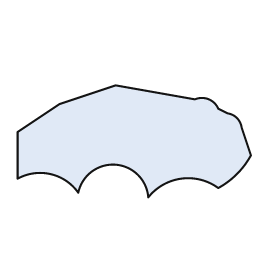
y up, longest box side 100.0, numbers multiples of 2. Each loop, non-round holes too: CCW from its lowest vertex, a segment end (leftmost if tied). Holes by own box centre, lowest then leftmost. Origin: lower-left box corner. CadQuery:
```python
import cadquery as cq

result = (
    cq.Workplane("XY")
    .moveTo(56.0, 0.0)
    .threePointArc((70.0, 8.0), (86.0, 4.0))
    .threePointArc((94.0, 10.0), (100.0, 18.0))
    .lineTo(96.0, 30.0)
    .threePointArc((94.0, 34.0), (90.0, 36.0))
    .lineTo(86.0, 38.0)
    .threePointArc((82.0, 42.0), (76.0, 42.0))
    .lineTo(42.0, 48.0)
    .lineTo(18.0, 40.0)
    .lineTo(0.0, 28.0)
    .lineTo(0.0, 8.0)
    .threePointArc((14.0, 10.0), (26.0, 2.0))
    .threePointArc((42.0, 14.0), (56.0, 0.0))
    .close()
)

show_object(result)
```